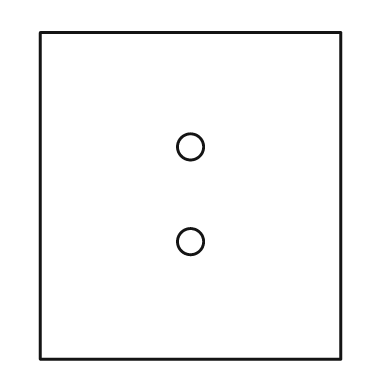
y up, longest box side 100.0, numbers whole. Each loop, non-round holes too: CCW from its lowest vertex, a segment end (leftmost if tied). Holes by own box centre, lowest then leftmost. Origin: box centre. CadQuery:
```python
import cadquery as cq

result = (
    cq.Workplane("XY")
    .moveTo(-46.0, -50.0)
    .lineTo(46.0, -50.0)
    .lineTo(46.0, 50.0)
    .lineTo(-46.0, 50.0)
    .close()
    .moveTo(0.0, -14.0)
    .circle(4.0)
    .moveTo(0.0, 15.0)
    .circle(4.0)
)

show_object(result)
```